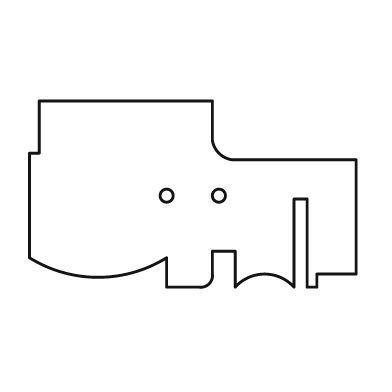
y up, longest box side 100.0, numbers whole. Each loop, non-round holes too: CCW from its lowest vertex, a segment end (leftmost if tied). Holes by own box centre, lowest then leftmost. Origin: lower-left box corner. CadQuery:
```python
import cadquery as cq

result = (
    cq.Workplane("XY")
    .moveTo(42.0, 0.0)
    .lineTo(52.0, 0.0)
    .threePointArc((55.0, 1.0), (56.0, 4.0))
    .lineTo(56.0, 11.0)
    .lineTo(63.0, 11.0)
    .lineTo(63.0, 0.0)
    .threePointArc((72.0, 4.0), (81.0, 0.0))
    .lineTo(81.0, 27.0)
    .lineTo(85.0, 27.0)
    .lineTo(85.0, 0.0)
    .lineTo(88.0, 0.0)
    .lineTo(88.0, 4.0)
    .lineTo(100.0, 4.0)
    .lineTo(100.0, 39.0)
    .lineTo(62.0, 39.0)
    .threePointArc((58.0, 41.0), (56.0, 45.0))
    .lineTo(56.0, 57.0)
    .lineTo(3.0, 57.0)
    .lineTo(3.0, 41.0)
    .lineTo(0.0, 41.0)
    .lineTo(0.0, 9.0)
    .threePointArc((21.0, 3.0), (42.0, 9.0))
    .close()
    .moveTo(42.0, 28.0)
    .circle(2.0)
    .moveTo(58.0, 28.0)
    .circle(2.0)
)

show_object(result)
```